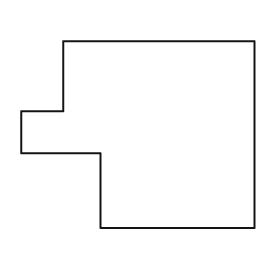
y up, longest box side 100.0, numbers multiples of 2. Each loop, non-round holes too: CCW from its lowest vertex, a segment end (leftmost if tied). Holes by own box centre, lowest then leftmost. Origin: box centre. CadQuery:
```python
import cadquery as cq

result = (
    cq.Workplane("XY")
    .moveTo(-16.0, -40.0)
    .lineTo(50.0, -40.0)
    .lineTo(50.0, 40.0)
    .lineTo(-32.0, 40.0)
    .lineTo(-32.0, 10.0)
    .lineTo(-50.0, 10.0)
    .lineTo(-50.0, -8.0)
    .lineTo(-16.0, -8.0)
    .close()
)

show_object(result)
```